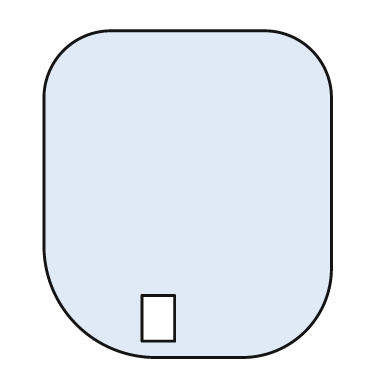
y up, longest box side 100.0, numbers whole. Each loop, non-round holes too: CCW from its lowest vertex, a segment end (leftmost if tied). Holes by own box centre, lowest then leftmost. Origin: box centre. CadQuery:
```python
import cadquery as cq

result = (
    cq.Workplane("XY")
    .moveTo(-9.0, -50.0)
    .lineTo(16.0, -50.0)
    .threePointArc((36.0, -42.0), (44.0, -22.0))
    .lineTo(44.0, 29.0)
    .threePointArc((38.0, 44.0), (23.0, 50.0))
    .lineTo(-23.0, 50.0)
    .threePointArc((-38.0, 44.0), (-44.0, 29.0))
    .lineTo(-44.0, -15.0)
    .threePointArc((-34.0, -40.0), (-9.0, -50.0))
    .close()
    .moveTo(-14.0, -45.0)
    .lineTo(-4.0, -45.0)
    .lineTo(-4.0, -31.0)
    .lineTo(-14.0, -31.0)
    .close()
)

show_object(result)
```